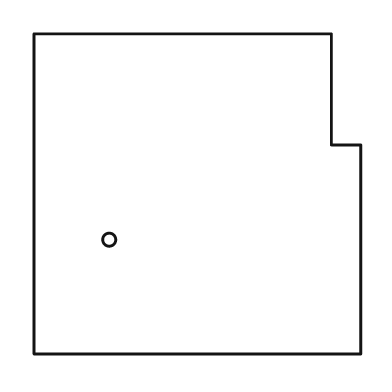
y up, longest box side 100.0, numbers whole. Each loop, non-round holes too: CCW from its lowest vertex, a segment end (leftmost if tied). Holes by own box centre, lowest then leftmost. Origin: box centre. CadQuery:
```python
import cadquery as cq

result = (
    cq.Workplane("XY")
    .moveTo(-50.0, -49.0)
    .lineTo(50.0, -49.0)
    .lineTo(50.0, 15.0)
    .lineTo(41.0, 15.0)
    .lineTo(41.0, 49.0)
    .lineTo(-50.0, 49.0)
    .close()
    .moveTo(-27.0, -14.0)
    .circle(2.0)
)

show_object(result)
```